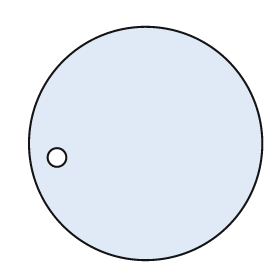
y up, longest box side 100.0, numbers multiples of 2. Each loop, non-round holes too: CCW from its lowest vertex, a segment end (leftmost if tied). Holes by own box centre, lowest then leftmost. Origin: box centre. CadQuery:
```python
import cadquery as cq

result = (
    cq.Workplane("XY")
    .moveTo(0.0, 0.0)
    .circle(50.0)
    .moveTo(-38.0, -6.0)
    .circle(4.0)
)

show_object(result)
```